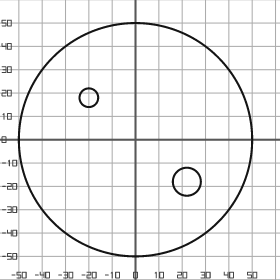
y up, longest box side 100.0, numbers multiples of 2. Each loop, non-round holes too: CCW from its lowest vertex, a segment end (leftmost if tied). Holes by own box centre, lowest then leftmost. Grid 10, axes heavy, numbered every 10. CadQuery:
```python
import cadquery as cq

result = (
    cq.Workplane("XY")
    .moveTo(0.0, 0.0)
    .circle(50.0)
    .moveTo(22.0, -18.0)
    .circle(6.0)
    .moveTo(-20.0, 18.0)
    .circle(4.0)
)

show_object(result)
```